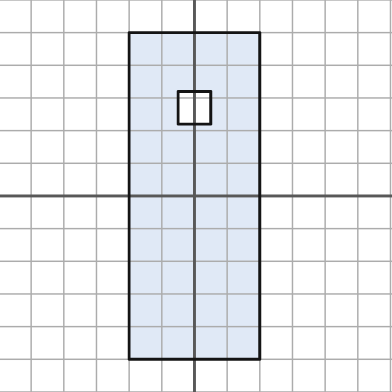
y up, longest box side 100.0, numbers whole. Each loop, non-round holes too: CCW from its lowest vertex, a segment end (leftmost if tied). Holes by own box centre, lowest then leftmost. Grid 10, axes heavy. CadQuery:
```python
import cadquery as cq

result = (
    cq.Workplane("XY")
    .moveTo(-20.0, -50.0)
    .lineTo(20.0, -50.0)
    .lineTo(20.0, 50.0)
    .lineTo(-20.0, 50.0)
    .close()
    .moveTo(-5.0, 22.0)
    .lineTo(5.0, 22.0)
    .lineTo(5.0, 32.0)
    .lineTo(-5.0, 32.0)
    .close()
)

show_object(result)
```